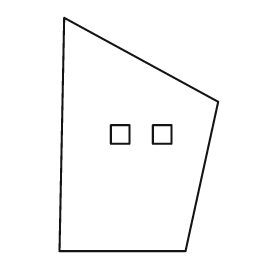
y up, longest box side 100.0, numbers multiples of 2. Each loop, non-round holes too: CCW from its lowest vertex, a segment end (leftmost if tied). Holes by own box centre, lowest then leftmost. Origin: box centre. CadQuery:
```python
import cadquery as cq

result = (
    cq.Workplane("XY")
    .moveTo(-34.0, -50.0)
    .lineTo(20.0, -50.0)
    .lineTo(34.0, 14.0)
    .lineTo(-32.0, 50.0)
    .close()
    .moveTo(-12.0, -4.0)
    .lineTo(-4.0, -4.0)
    .lineTo(-4.0, 4.0)
    .lineTo(-12.0, 4.0)
    .close()
    .moveTo(6.0, -4.0)
    .lineTo(14.0, -4.0)
    .lineTo(14.0, 4.0)
    .lineTo(6.0, 4.0)
    .close()
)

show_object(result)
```